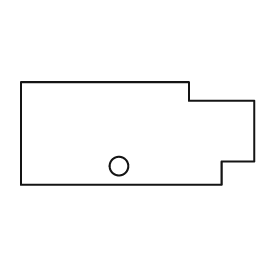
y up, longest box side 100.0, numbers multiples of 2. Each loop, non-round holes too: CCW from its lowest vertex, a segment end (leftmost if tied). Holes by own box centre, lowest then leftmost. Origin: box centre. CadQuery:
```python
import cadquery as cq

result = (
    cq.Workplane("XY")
    .moveTo(-50.0, -22.0)
    .lineTo(36.0, -22.0)
    .lineTo(36.0, -12.0)
    .lineTo(50.0, -12.0)
    .lineTo(50.0, 14.0)
    .lineTo(22.0, 14.0)
    .lineTo(22.0, 22.0)
    .lineTo(-50.0, 22.0)
    .close()
    .moveTo(-8.0, -14.0)
    .circle(4.0)
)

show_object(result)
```